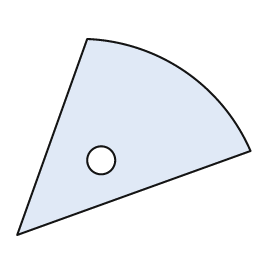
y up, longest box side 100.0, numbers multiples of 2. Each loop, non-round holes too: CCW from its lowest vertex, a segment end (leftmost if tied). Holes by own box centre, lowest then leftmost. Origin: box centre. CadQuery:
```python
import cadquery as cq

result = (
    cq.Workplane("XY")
    .moveTo(-50.0, -42.0)
    .lineTo(50.0, -6.0)
    .threePointArc((22.0, 28.0), (-20.0, 42.0))
    .close()
    .moveTo(-14.0, -10.0)
    .circle(6.0)
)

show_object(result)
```